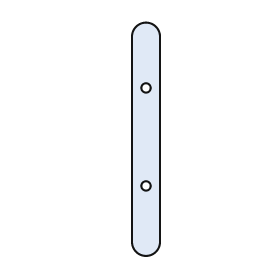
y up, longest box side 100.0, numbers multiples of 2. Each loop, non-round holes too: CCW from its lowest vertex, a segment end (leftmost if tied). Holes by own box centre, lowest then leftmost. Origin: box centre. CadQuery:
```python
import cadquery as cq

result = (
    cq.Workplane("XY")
    .moveTo(-6.0, -44.0)
    .threePointArc((0.0, -50.0), (6.0, -44.0))
    .lineTo(6.0, 44.0)
    .threePointArc((0.0, 50.0), (-6.0, 44.0))
    .close()
    .moveTo(0.0, -20.0)
    .circle(2.0)
    .moveTo(0.0, 22.0)
    .circle(2.0)
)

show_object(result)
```